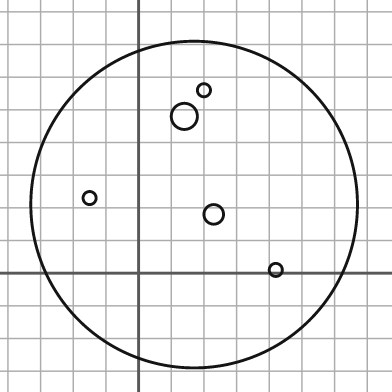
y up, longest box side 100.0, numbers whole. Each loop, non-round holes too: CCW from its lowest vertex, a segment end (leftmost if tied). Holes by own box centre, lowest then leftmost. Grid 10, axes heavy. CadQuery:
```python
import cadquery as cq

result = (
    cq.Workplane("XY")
    .moveTo(17.0, 21.0)
    .circle(50.0)
    .moveTo(42.0, 1.0)
    .circle(2.0)
    .moveTo(23.0, 18.0)
    .circle(3.0)
    .moveTo(-15.0, 23.0)
    .circle(2.0)
    .moveTo(14.0, 48.0)
    .circle(4.0)
    .moveTo(20.0, 56.0)
    .circle(2.0)
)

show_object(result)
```